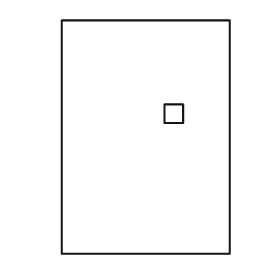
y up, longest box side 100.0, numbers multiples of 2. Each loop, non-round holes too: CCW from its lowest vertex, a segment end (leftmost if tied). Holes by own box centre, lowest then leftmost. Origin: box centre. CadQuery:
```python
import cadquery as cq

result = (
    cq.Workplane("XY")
    .moveTo(-36.0, -50.0)
    .lineTo(36.0, -50.0)
    .lineTo(36.0, 50.0)
    .lineTo(-36.0, 50.0)
    .close()
    .moveTo(8.0, 6.0)
    .lineTo(16.0, 6.0)
    .lineTo(16.0, 14.0)
    .lineTo(8.0, 14.0)
    .close()
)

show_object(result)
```